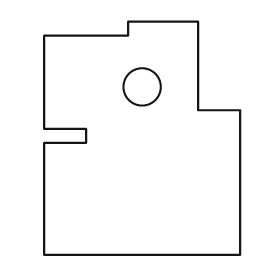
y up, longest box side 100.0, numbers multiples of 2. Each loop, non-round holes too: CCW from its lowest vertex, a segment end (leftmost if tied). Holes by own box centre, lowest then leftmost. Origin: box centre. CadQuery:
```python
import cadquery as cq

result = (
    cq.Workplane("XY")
    .moveTo(-42.0, -50.0)
    .lineTo(42.0, -50.0)
    .lineTo(42.0, 12.0)
    .lineTo(24.0, 12.0)
    .lineTo(24.0, 50.0)
    .lineTo(-6.0, 50.0)
    .lineTo(-6.0, 44.0)
    .lineTo(-42.0, 44.0)
    .lineTo(-42.0, 4.0)
    .lineTo(-24.0, 4.0)
    .lineTo(-24.0, -2.0)
    .lineTo(-42.0, -2.0)
    .close()
    .moveTo(0.0, 22.0)
    .circle(8.0)
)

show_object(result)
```